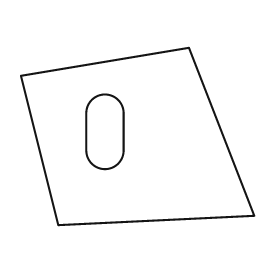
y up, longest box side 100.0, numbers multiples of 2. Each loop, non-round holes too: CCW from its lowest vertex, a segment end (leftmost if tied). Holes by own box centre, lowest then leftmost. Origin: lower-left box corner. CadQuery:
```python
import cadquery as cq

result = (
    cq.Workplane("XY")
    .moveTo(16.0, 0.0)
    .lineTo(100.0, 4.0)
    .lineTo(72.0, 76.0)
    .lineTo(0.0, 64.0)
    .close()
    .moveTo(28.0, 32.0)
    .threePointArc((36.0, 24.0), (44.0, 32.0))
    .lineTo(44.0, 48.0)
    .threePointArc((36.0, 56.0), (28.0, 48.0))
    .close()
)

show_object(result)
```